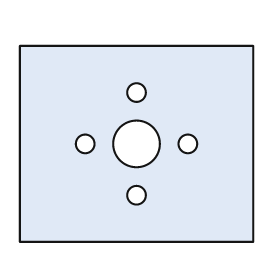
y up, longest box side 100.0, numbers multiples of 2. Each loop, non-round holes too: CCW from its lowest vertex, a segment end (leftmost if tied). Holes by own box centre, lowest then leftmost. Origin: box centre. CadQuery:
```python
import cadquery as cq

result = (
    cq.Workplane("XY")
    .moveTo(-50.0, -42.0)
    .lineTo(50.0, -42.0)
    .lineTo(50.0, 42.0)
    .lineTo(-50.0, 42.0)
    .close()
    .moveTo(0.0, -22.0)
    .circle(4.0)
    .moveTo(-22.0, 0.0)
    .circle(4.0)
    .moveTo(0.0, 0.0)
    .circle(10.0)
    .moveTo(22.0, 0.0)
    .circle(4.0)
    .moveTo(0.0, 22.0)
    .circle(4.0)
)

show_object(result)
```